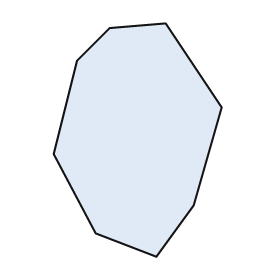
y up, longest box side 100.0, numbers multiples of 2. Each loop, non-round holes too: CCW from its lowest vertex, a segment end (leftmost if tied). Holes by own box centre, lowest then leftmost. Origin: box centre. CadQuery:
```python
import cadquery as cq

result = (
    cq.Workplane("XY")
    .moveTo(8.0, -50.0)
    .lineTo(24.0, -28.0)
    .lineTo(36.0, 14.0)
    .lineTo(12.0, 50.0)
    .lineTo(-12.0, 48.0)
    .lineTo(-26.0, 34.0)
    .lineTo(-36.0, -6.0)
    .lineTo(-18.0, -40.0)
    .close()
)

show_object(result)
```